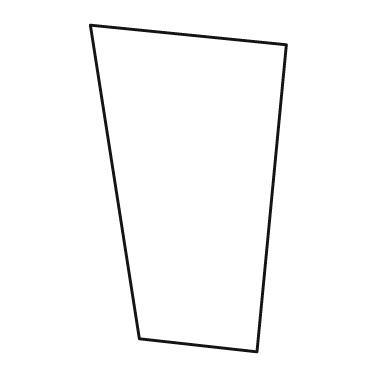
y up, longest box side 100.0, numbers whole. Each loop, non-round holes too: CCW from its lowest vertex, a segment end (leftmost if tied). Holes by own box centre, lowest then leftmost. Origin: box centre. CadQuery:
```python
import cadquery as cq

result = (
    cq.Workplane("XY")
    .moveTo(21.0, -50.0)
    .lineTo(30.0, 44.0)
    .lineTo(-30.0, 50.0)
    .lineTo(-15.0, -46.0)
    .close()
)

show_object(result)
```